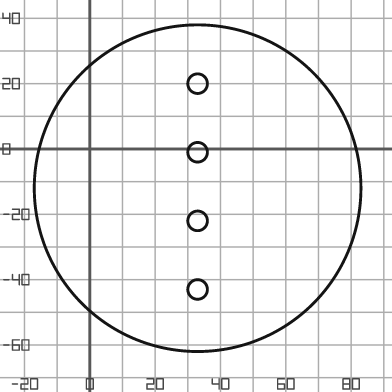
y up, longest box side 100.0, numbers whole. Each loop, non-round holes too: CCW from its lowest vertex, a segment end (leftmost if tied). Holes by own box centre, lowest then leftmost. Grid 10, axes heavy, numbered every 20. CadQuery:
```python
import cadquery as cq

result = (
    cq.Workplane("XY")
    .moveTo(33.0, -12.0)
    .circle(50.0)
    .moveTo(33.0, -43.0)
    .circle(3.0)
    .moveTo(33.0, -22.0)
    .circle(3.0)
    .moveTo(33.0, -1.0)
    .circle(3.0)
    .moveTo(33.0, 20.0)
    .circle(3.0)
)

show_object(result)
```